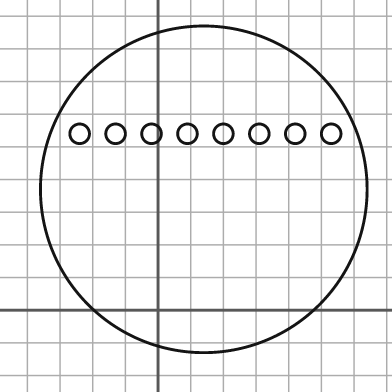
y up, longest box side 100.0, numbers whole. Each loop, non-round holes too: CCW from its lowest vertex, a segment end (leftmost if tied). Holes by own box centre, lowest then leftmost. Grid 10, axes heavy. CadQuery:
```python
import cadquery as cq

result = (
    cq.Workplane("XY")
    .moveTo(14.0, 37.0)
    .circle(50.0)
    .moveTo(-24.0, 54.0)
    .circle(3.0)
    .moveTo(-13.0, 54.0)
    .circle(3.0)
    .moveTo(-2.0, 54.0)
    .circle(3.0)
    .moveTo(9.0, 54.0)
    .circle(3.0)
    .moveTo(20.0, 54.0)
    .circle(3.0)
    .moveTo(31.0, 54.0)
    .circle(3.0)
    .moveTo(42.0, 54.0)
    .circle(3.0)
    .moveTo(53.0, 54.0)
    .circle(3.0)
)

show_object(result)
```